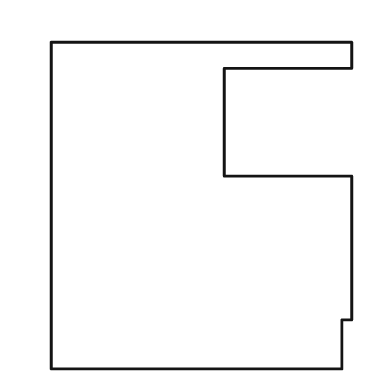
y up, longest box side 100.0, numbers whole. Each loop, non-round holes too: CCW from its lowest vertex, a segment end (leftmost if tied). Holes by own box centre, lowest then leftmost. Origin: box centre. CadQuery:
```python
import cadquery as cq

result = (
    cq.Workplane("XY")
    .moveTo(-46.0, -50.0)
    .lineTo(43.0, -50.0)
    .lineTo(43.0, -35.0)
    .lineTo(46.0, -35.0)
    .lineTo(46.0, 9.0)
    .lineTo(7.0, 9.0)
    .lineTo(7.0, 42.0)
    .lineTo(46.0, 42.0)
    .lineTo(46.0, 50.0)
    .lineTo(-46.0, 50.0)
    .close()
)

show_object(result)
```